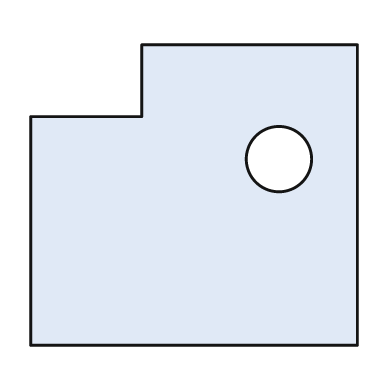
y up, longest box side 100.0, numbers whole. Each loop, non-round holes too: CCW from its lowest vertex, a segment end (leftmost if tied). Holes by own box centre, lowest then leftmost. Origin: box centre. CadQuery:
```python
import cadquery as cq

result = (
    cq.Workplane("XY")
    .moveTo(-50.0, -46.0)
    .lineTo(50.0, -46.0)
    .lineTo(50.0, 46.0)
    .lineTo(-16.0, 46.0)
    .lineTo(-16.0, 24.0)
    .lineTo(-50.0, 24.0)
    .close()
    .moveTo(26.0, 11.0)
    .circle(10.0)
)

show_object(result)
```